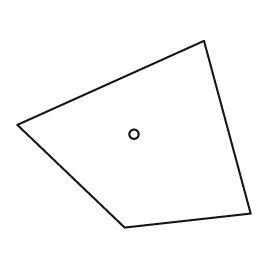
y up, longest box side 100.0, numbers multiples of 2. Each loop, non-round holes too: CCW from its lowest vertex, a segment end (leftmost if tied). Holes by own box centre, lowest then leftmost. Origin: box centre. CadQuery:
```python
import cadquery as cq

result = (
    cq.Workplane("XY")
    .moveTo(-4.0, -40.0)
    .lineTo(50.0, -34.0)
    .lineTo(30.0, 40.0)
    .lineTo(-50.0, 4.0)
    .close()
    .moveTo(0.0, 0.0)
    .circle(2.0)
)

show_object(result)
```